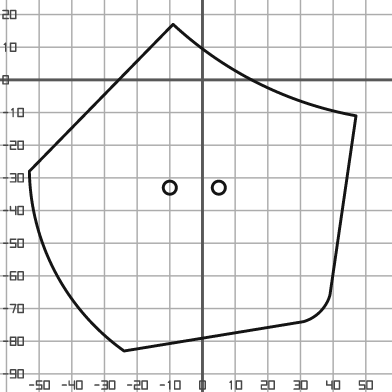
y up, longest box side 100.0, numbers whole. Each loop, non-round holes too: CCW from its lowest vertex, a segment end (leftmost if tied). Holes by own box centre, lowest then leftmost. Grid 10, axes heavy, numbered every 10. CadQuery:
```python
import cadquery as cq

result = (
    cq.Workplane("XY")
    .moveTo(-24.0, -83.0)
    .lineTo(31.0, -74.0)
    .threePointArc((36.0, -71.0), (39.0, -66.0))
    .lineTo(47.0, -11.0)
    .threePointArc((17.0, -1.0), (-9.0, 17.0))
    .lineTo(-53.0, -28.0)
    .threePointArc((-45.0, -59.0), (-24.0, -83.0))
    .close()
    .moveTo(-10.0, -33.0)
    .circle(2.0)
    .moveTo(5.0, -33.0)
    .circle(2.0)
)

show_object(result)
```